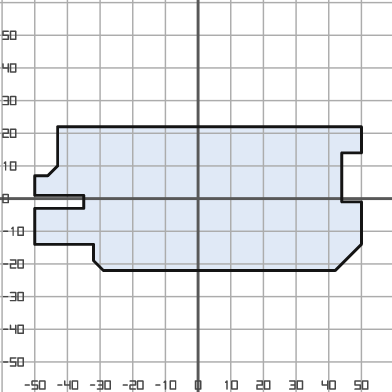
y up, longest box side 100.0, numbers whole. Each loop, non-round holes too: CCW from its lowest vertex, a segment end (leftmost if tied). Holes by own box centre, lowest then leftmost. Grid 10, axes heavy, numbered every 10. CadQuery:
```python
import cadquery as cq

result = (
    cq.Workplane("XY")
    .moveTo(-29.0, -22.0)
    .lineTo(42.0, -22.0)
    .lineTo(50.0, -14.0)
    .lineTo(50.0, -1.0)
    .lineTo(44.0, -1.0)
    .lineTo(44.0, 14.0)
    .lineTo(50.0, 14.0)
    .lineTo(50.0, 22.0)
    .lineTo(-43.0, 22.0)
    .lineTo(-43.0, 10.0)
    .lineTo(-46.0, 7.0)
    .lineTo(-50.0, 7.0)
    .lineTo(-50.0, 1.0)
    .lineTo(-35.0, 1.0)
    .lineTo(-35.0, -3.0)
    .lineTo(-50.0, -3.0)
    .lineTo(-50.0, -14.0)
    .lineTo(-32.0, -14.0)
    .lineTo(-32.0, -19.0)
    .close()
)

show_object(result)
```